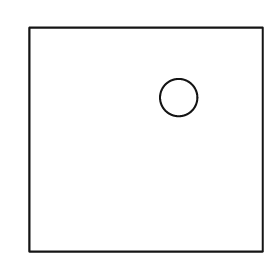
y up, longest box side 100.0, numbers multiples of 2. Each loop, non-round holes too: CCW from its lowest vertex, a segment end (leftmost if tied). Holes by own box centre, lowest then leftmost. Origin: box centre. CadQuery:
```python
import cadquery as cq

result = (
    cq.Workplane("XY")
    .moveTo(-50.0, -48.0)
    .lineTo(50.0, -48.0)
    .lineTo(50.0, 48.0)
    .lineTo(-50.0, 48.0)
    .close()
    .moveTo(14.0, 18.0)
    .circle(8.0)
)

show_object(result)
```